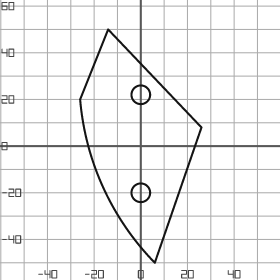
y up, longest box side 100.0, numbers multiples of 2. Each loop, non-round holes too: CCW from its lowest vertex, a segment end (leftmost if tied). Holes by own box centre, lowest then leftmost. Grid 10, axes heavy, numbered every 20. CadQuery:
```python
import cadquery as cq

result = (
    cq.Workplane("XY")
    .moveTo(6.0, -50.0)
    .lineTo(26.0, 8.0)
    .lineTo(-14.0, 50.0)
    .lineTo(-26.0, 20.0)
    .threePointArc((-16.0, -18.0), (6.0, -50.0))
    .close()
    .moveTo(0.0, -20.0)
    .circle(4.0)
    .moveTo(0.0, 22.0)
    .circle(4.0)
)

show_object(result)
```